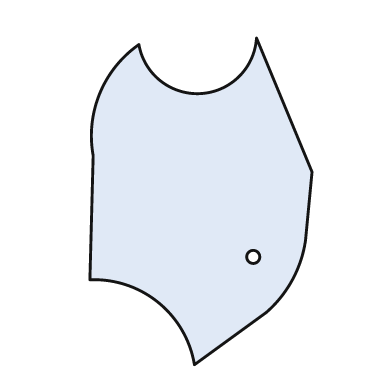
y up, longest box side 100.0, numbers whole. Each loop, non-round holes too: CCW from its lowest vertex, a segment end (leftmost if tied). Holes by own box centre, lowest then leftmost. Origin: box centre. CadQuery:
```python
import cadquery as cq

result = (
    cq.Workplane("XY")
    .moveTo(-2.0, -50.0)
    .lineTo(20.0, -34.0)
    .threePointArc((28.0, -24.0), (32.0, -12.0))
    .lineTo(34.0, 9.0)
    .lineTo(17.0, 50.0)
    .threePointArc((0.0, 33.0), (-19.0, 48.0))
    .threePointArc((-31.0, 33.0), (-33.0, 14.0))
    .lineTo(-34.0, -24.0)
    .threePointArc((-13.0, -31.0), (-2.0, -50.0))
    .close()
    .moveTo(16.0, -17.0)
    .circle(2.0)
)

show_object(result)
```